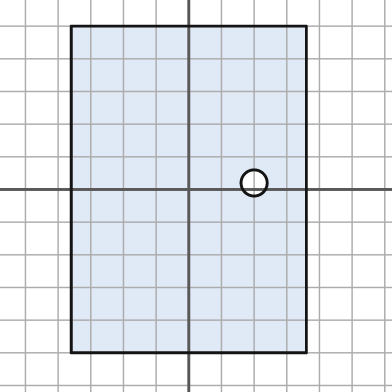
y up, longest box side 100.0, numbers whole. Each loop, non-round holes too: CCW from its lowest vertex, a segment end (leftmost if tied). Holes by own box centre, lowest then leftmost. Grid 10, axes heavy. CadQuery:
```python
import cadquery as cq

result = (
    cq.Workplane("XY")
    .moveTo(-36.0, -50.0)
    .lineTo(36.0, -50.0)
    .lineTo(36.0, 50.0)
    .lineTo(-36.0, 50.0)
    .close()
    .moveTo(20.0, 2.0)
    .circle(4.0)
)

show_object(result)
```